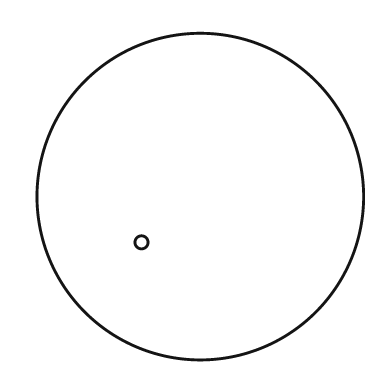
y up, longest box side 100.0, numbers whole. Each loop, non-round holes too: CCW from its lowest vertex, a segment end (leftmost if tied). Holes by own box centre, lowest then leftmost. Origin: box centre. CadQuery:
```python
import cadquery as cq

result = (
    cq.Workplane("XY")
    .moveTo(0.0, 0.0)
    .circle(50.0)
    .moveTo(-18.0, -14.0)
    .circle(2.0)
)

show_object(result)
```